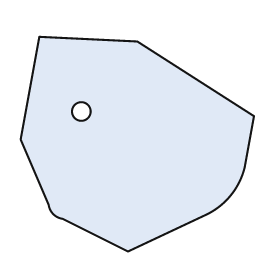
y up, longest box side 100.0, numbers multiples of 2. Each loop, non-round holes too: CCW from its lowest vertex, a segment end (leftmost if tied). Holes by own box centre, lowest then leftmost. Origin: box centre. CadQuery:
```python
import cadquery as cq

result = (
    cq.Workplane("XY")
    .moveTo(-4.0, -46.0)
    .lineTo(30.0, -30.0)
    .threePointArc((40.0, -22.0), (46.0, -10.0))
    .lineTo(50.0, 12.0)
    .lineTo(0.0, 44.0)
    .lineTo(-42.0, 46.0)
    .lineTo(-50.0, 2.0)
    .lineTo(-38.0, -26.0)
    .threePointArc((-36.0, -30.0), (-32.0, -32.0))
    .close()
    .moveTo(-24.0, 14.0)
    .circle(4.0)
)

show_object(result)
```